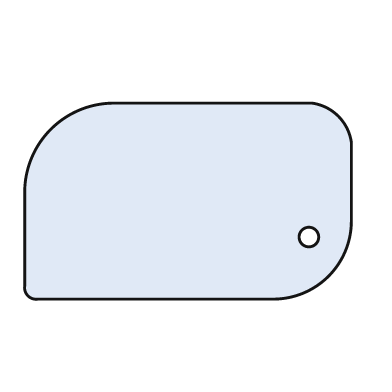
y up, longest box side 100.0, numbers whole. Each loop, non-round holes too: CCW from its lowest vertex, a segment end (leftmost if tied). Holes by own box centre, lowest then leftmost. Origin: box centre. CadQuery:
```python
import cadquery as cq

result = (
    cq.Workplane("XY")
    .moveTo(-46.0, -30.0)
    .lineTo(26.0, -30.0)
    .threePointArc((43.0, -23.0), (50.0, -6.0))
    .lineTo(50.0, 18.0)
    .threePointArc((46.0, 26.0), (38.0, 30.0))
    .lineTo(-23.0, 30.0)
    .threePointArc((-42.0, 22.0), (-50.0, 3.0))
    .lineTo(-50.0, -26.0)
    .threePointArc((-49.0, -29.0), (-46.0, -30.0))
    .close()
    .moveTo(37.0, -11.0)
    .circle(3.0)
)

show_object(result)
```